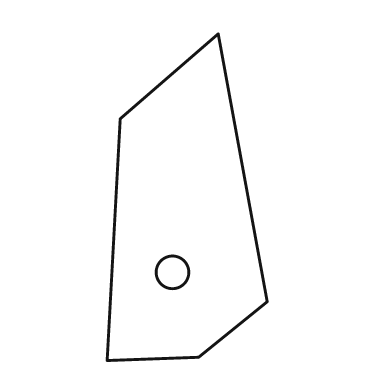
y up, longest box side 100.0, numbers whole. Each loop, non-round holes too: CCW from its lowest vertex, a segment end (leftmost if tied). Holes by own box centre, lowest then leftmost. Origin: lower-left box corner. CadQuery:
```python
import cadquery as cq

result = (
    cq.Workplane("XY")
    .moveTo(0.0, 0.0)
    .lineTo(28.0, 1.0)
    .lineTo(49.0, 18.0)
    .lineTo(34.0, 100.0)
    .lineTo(4.0, 74.0)
    .close()
    .moveTo(20.0, 27.0)
    .circle(5.0)
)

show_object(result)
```